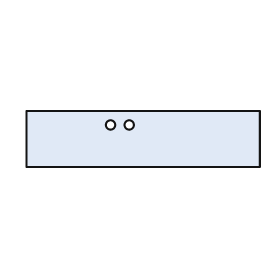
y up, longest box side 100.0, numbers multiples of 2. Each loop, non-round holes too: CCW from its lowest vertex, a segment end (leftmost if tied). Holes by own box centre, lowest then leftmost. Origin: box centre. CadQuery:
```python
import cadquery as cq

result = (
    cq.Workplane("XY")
    .moveTo(-50.0, -12.0)
    .lineTo(50.0, -12.0)
    .lineTo(50.0, 12.0)
    .lineTo(-50.0, 12.0)
    .close()
    .moveTo(-14.0, 6.0)
    .circle(2.0)
    .moveTo(-6.0, 6.0)
    .circle(2.0)
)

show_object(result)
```